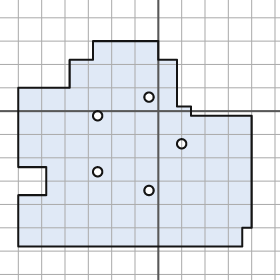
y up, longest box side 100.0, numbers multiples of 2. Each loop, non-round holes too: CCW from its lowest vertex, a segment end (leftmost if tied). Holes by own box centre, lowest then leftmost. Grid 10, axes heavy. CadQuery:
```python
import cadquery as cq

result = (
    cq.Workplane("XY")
    .moveTo(-60.0, -58.0)
    .lineTo(36.0, -58.0)
    .lineTo(36.0, -50.0)
    .lineTo(40.0, -50.0)
    .lineTo(40.0, -2.0)
    .lineTo(14.0, -2.0)
    .lineTo(14.0, 2.0)
    .lineTo(8.0, 2.0)
    .lineTo(8.0, 22.0)
    .lineTo(0.0, 22.0)
    .lineTo(0.0, 30.0)
    .lineTo(-28.0, 30.0)
    .lineTo(-28.0, 22.0)
    .lineTo(-38.0, 22.0)
    .lineTo(-38.0, 10.0)
    .lineTo(-60.0, 10.0)
    .lineTo(-60.0, -24.0)
    .lineTo(-48.0, -24.0)
    .lineTo(-48.0, -36.0)
    .lineTo(-60.0, -36.0)
    .close()
    .moveTo(-4.0, -34.0)
    .circle(2.0)
    .moveTo(-26.0, -26.0)
    .circle(2.0)
    .moveTo(10.0, -14.0)
    .circle(2.0)
    .moveTo(-26.0, -2.0)
    .circle(2.0)
    .moveTo(-4.0, 6.0)
    .circle(2.0)
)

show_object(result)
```